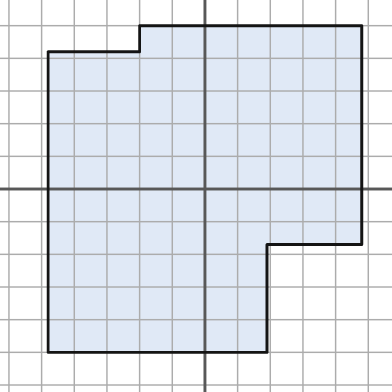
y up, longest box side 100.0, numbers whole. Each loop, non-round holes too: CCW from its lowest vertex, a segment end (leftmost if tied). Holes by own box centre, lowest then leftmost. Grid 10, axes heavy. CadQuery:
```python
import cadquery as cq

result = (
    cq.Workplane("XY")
    .moveTo(-48.0, -50.0)
    .lineTo(19.0, -50.0)
    .lineTo(19.0, -17.0)
    .lineTo(48.0, -17.0)
    .lineTo(48.0, 50.0)
    .lineTo(-20.0, 50.0)
    .lineTo(-20.0, 42.0)
    .lineTo(-48.0, 42.0)
    .close()
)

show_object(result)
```